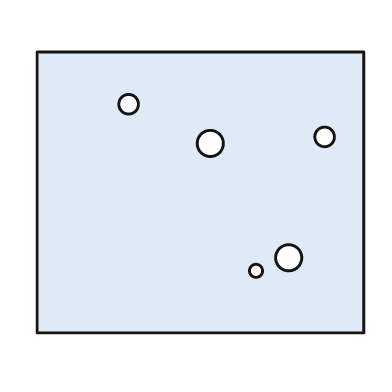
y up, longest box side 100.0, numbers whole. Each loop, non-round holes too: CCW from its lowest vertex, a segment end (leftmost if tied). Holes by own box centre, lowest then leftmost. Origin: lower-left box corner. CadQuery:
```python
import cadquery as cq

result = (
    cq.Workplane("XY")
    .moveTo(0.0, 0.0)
    .lineTo(100.0, 0.0)
    .lineTo(100.0, 86.0)
    .lineTo(0.0, 86.0)
    .close()
    .moveTo(67.0, 19.0)
    .circle(2.0)
    .moveTo(77.0, 23.0)
    .circle(4.0)
    .moveTo(53.0, 58.0)
    .circle(4.0)
    .moveTo(88.0, 60.0)
    .circle(3.0)
    .moveTo(28.0, 70.0)
    .circle(3.0)
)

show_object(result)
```